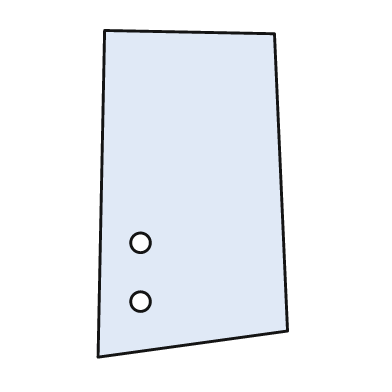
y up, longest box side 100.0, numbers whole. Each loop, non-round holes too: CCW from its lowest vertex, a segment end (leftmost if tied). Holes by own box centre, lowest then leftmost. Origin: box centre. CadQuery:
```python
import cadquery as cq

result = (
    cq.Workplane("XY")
    .moveTo(-29.0, -50.0)
    .lineTo(29.0, -42.0)
    .lineTo(25.0, 49.0)
    .lineTo(-27.0, 50.0)
    .close()
    .moveTo(-16.0, -33.0)
    .circle(3.0)
    .moveTo(-16.0, -15.0)
    .circle(3.0)
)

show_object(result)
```